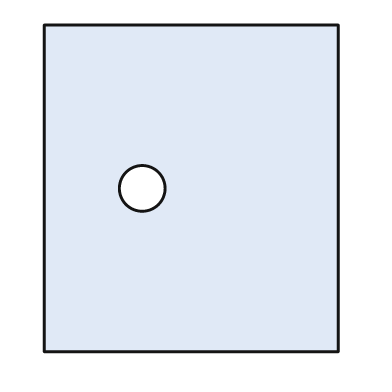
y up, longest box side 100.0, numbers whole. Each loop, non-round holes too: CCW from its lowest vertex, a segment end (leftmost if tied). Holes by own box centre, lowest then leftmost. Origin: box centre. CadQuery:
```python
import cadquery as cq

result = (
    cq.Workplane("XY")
    .moveTo(-45.0, -50.0)
    .lineTo(45.0, -50.0)
    .lineTo(45.0, 50.0)
    .lineTo(-45.0, 50.0)
    .close()
    .moveTo(-15.0, 0.0)
    .circle(7.0)
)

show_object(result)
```